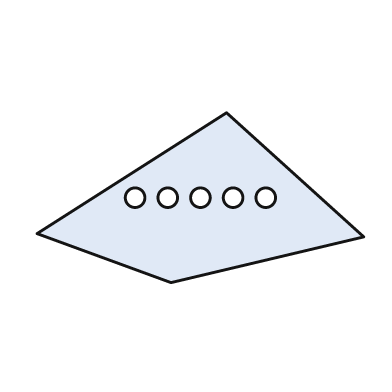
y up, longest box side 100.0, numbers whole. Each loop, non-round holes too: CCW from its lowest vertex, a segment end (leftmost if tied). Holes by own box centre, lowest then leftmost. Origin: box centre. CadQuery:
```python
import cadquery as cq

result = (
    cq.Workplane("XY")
    .moveTo(-9.0, -26.0)
    .lineTo(50.0, -12.0)
    .lineTo(8.0, 26.0)
    .lineTo(-50.0, -11.0)
    .close()
    .moveTo(-20.0, 0.0)
    .circle(3.0)
    .moveTo(-10.0, 0.0)
    .circle(3.0)
    .moveTo(0.0, 0.0)
    .circle(3.0)
    .moveTo(10.0, 0.0)
    .circle(3.0)
    .moveTo(20.0, 0.0)
    .circle(3.0)
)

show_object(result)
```